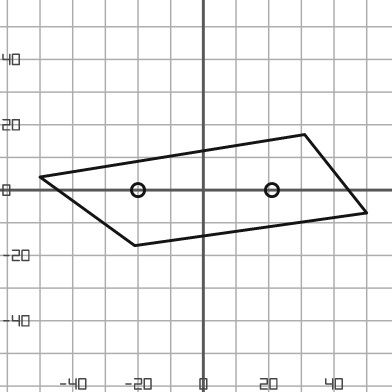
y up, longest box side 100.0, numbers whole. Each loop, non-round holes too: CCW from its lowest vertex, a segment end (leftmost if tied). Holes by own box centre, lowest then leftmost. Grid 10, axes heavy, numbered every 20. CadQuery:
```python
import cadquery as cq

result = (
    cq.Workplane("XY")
    .moveTo(-21.0, -17.0)
    .lineTo(50.0, -7.0)
    .lineTo(31.0, 17.0)
    .lineTo(-50.0, 4.0)
    .close()
    .moveTo(-20.0, 0.0)
    .circle(2.0)
    .moveTo(21.0, 0.0)
    .circle(2.0)
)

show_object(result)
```